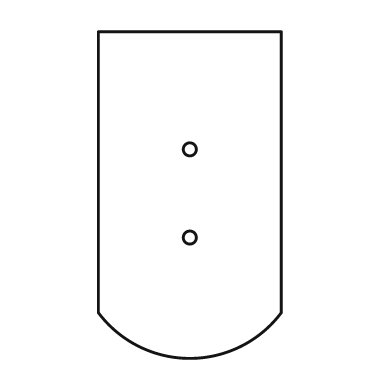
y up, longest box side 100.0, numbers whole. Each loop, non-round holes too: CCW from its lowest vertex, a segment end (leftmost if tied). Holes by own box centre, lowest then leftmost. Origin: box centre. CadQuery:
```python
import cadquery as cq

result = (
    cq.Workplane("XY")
    .moveTo(-28.0, -36.0)
    .threePointArc((0.0, -50.0), (28.0, -36.0))
    .lineTo(28.0, 50.0)
    .lineTo(-28.0, 50.0)
    .close()
    .moveTo(0.0, -13.0)
    .circle(2.0)
    .moveTo(0.0, 14.0)
    .circle(2.0)
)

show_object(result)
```